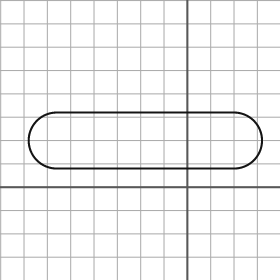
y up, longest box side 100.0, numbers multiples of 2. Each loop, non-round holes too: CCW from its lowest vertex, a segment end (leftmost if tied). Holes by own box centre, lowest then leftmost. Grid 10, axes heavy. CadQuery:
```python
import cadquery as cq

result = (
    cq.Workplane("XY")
    .moveTo(-56.0, 8.0)
    .lineTo(20.0, 8.0)
    .threePointArc((32.0, 20.0), (20.0, 32.0))
    .lineTo(-56.0, 32.0)
    .threePointArc((-68.0, 20.0), (-56.0, 8.0))
    .close()
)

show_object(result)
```